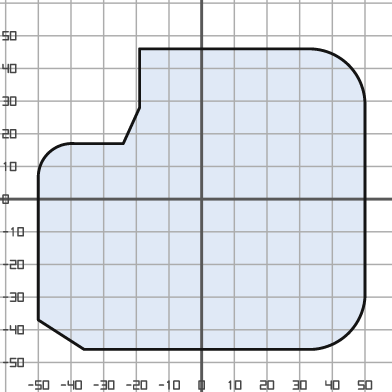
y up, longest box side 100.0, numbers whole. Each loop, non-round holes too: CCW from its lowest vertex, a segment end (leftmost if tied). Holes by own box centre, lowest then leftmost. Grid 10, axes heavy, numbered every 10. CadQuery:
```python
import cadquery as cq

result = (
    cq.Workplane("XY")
    .moveTo(-36.0, -46.0)
    .lineTo(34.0, -46.0)
    .threePointArc((45.0, -41.0), (50.0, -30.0))
    .lineTo(50.0, 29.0)
    .threePointArc((45.0, 41.0), (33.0, 46.0))
    .lineTo(-19.0, 46.0)
    .lineTo(-19.0, 28.0)
    .lineTo(-24.0, 17.0)
    .lineTo(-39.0, 17.0)
    .threePointArc((-47.0, 14.0), (-50.0, 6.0))
    .lineTo(-50.0, -37.0)
    .close()
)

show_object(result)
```